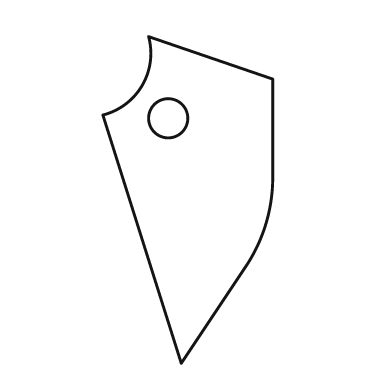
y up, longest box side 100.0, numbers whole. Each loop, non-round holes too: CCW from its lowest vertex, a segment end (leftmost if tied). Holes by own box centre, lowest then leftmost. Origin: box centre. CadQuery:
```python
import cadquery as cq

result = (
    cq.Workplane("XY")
    .moveTo(-2.0, -50.0)
    .lineTo(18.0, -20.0)
    .threePointArc((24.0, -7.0), (26.0, 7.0))
    .lineTo(26.0, 37.0)
    .lineTo(-12.0, 50.0)
    .threePointArc((-14.0, 35.0), (-26.0, 26.0))
    .close()
    .moveTo(-6.0, 25.0)
    .circle(6.0)
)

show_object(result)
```